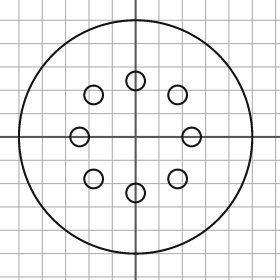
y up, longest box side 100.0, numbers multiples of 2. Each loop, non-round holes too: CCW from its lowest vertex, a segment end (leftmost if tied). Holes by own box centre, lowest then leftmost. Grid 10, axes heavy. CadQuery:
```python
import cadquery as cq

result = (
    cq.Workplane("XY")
    .moveTo(0.0, 0.0)
    .circle(50.0)
    .moveTo(0.0, -24.0)
    .circle(4.0)
    .moveTo(-18.0, -18.0)
    .circle(4.0)
    .moveTo(18.0, -18.0)
    .circle(4.0)
    .moveTo(-24.0, 0.0)
    .circle(4.0)
    .moveTo(24.0, 0.0)
    .circle(4.0)
    .moveTo(-18.0, 18.0)
    .circle(4.0)
    .moveTo(18.0, 18.0)
    .circle(4.0)
    .moveTo(0.0, 24.0)
    .circle(4.0)
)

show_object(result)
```